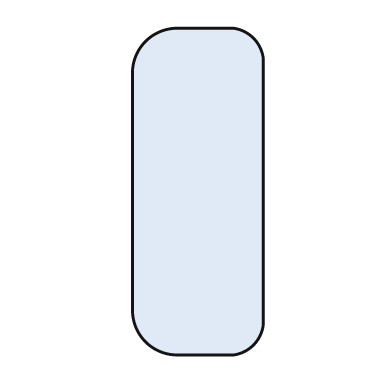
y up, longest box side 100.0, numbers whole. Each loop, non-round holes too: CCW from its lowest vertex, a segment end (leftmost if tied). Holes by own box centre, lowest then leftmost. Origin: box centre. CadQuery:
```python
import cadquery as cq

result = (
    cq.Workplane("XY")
    .moveTo(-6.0, -50.0)
    .lineTo(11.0, -50.0)
    .threePointArc((17.0, -47.0), (20.0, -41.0))
    .lineTo(20.0, 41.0)
    .threePointArc((17.0, 47.0), (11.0, 50.0))
    .lineTo(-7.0, 50.0)
    .threePointArc((-16.0, 46.0), (-20.0, 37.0))
    .lineTo(-20.0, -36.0)
    .threePointArc((-16.0, -46.0), (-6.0, -50.0))
    .close()
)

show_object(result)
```